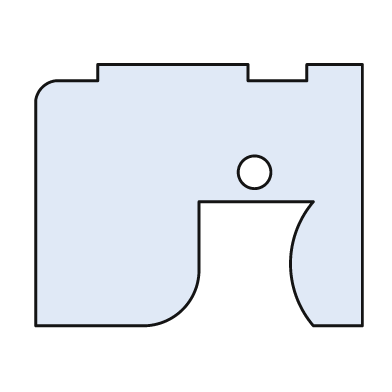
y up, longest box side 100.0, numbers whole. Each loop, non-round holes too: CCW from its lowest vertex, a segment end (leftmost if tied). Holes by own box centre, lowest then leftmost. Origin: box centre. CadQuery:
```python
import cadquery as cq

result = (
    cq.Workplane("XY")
    .moveTo(-50.0, -40.0)
    .lineTo(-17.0, -40.0)
    .threePointArc((-5.0, -35.0), (0.0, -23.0))
    .lineTo(0.0, -2.0)
    .lineTo(35.0, -2.0)
    .threePointArc((28.0, -21.0), (35.0, -40.0))
    .lineTo(50.0, -40.0)
    .lineTo(50.0, 40.0)
    .lineTo(33.0, 40.0)
    .lineTo(33.0, 35.0)
    .lineTo(15.0, 35.0)
    .lineTo(15.0, 40.0)
    .lineTo(-31.0, 40.0)
    .lineTo(-31.0, 35.0)
    .lineTo(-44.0, 35.0)
    .threePointArc((-48.0, 33.0), (-50.0, 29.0))
    .close()
    .moveTo(17.0, 7.0)
    .circle(5.0)
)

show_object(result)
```